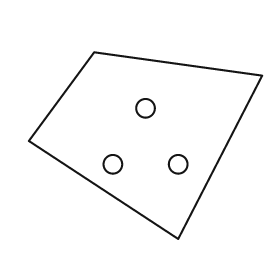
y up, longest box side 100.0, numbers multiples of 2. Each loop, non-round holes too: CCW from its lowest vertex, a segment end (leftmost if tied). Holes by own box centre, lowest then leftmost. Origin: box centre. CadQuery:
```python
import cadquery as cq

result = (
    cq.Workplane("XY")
    .moveTo(14.0, -40.0)
    .lineTo(50.0, 30.0)
    .lineTo(-22.0, 40.0)
    .lineTo(-50.0, 2.0)
    .close()
    .moveTo(-14.0, -8.0)
    .circle(4.0)
    .moveTo(14.0, -8.0)
    .circle(4.0)
    .moveTo(0.0, 16.0)
    .circle(4.0)
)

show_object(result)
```